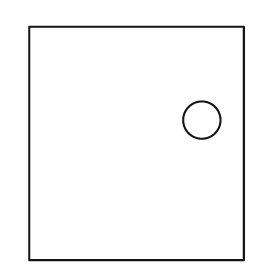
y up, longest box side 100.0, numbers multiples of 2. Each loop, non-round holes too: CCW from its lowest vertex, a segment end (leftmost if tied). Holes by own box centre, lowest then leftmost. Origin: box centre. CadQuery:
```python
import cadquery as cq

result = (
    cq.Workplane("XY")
    .moveTo(-46.0, -50.0)
    .lineTo(46.0, -50.0)
    .lineTo(46.0, 50.0)
    .lineTo(-46.0, 50.0)
    .close()
    .moveTo(28.0, 10.0)
    .circle(8.0)
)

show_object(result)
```